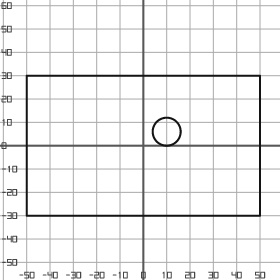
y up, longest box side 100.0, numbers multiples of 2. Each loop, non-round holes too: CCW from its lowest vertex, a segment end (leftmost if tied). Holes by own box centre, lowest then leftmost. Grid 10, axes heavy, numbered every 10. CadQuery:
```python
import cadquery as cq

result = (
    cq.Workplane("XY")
    .moveTo(-50.0, -30.0)
    .lineTo(50.0, -30.0)
    .lineTo(50.0, 30.0)
    .lineTo(-50.0, 30.0)
    .close()
    .moveTo(10.0, 6.0)
    .circle(6.0)
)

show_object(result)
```